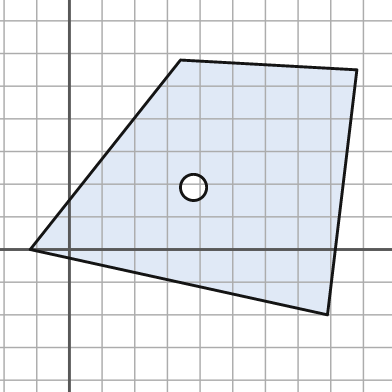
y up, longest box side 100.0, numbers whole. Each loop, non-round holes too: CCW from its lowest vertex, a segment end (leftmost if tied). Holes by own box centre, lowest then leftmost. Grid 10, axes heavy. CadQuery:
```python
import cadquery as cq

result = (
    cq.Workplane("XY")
    .moveTo(79.0, -20.0)
    .lineTo(88.0, 55.0)
    .lineTo(34.0, 58.0)
    .lineTo(-12.0, 0.0)
    .close()
    .moveTo(38.0, 19.0)
    .circle(4.0)
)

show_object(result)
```